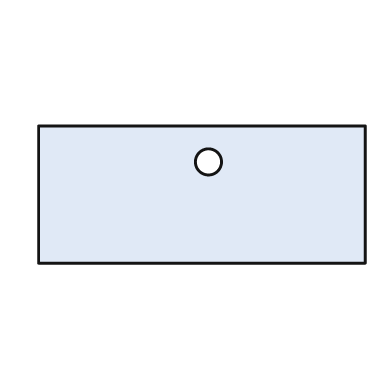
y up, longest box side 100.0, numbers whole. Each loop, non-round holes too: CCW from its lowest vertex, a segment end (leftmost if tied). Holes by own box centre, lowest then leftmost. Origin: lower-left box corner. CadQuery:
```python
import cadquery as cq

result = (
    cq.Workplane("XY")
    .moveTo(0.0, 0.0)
    .lineTo(100.0, 0.0)
    .lineTo(100.0, 42.0)
    .lineTo(0.0, 42.0)
    .close()
    .moveTo(52.0, 31.0)
    .circle(4.0)
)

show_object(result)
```